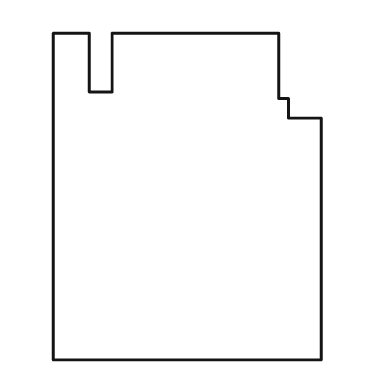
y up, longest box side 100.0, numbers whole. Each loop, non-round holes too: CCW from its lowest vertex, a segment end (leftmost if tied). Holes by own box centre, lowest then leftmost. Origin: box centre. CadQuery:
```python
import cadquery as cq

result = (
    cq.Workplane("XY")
    .moveTo(-41.0, -50.0)
    .lineTo(41.0, -50.0)
    .lineTo(41.0, 24.0)
    .lineTo(31.0, 24.0)
    .lineTo(31.0, 30.0)
    .lineTo(28.0, 30.0)
    .lineTo(28.0, 50.0)
    .lineTo(-23.0, 50.0)
    .lineTo(-23.0, 32.0)
    .lineTo(-30.0, 32.0)
    .lineTo(-30.0, 50.0)
    .lineTo(-41.0, 50.0)
    .close()
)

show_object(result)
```